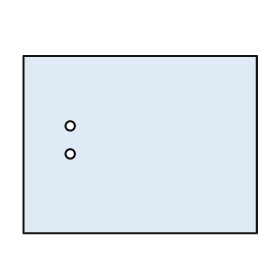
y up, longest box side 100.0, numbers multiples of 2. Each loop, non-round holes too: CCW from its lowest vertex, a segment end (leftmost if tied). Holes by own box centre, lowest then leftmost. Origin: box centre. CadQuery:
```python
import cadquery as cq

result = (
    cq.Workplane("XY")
    .moveTo(-50.0, -38.0)
    .lineTo(50.0, -38.0)
    .lineTo(50.0, 38.0)
    .lineTo(-50.0, 38.0)
    .close()
    .moveTo(-30.0, -4.0)
    .circle(2.0)
    .moveTo(-30.0, 8.0)
    .circle(2.0)
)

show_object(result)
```